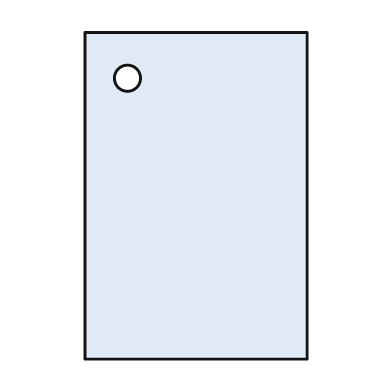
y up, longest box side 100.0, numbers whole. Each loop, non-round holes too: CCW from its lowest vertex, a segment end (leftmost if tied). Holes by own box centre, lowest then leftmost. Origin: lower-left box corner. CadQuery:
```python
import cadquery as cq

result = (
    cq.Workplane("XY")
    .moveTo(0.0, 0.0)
    .lineTo(68.0, 0.0)
    .lineTo(68.0, 100.0)
    .lineTo(0.0, 100.0)
    .close()
    .moveTo(13.0, 86.0)
    .circle(4.0)
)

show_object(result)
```